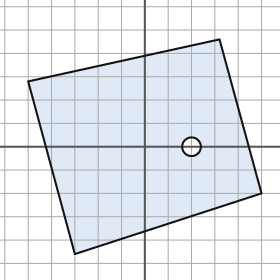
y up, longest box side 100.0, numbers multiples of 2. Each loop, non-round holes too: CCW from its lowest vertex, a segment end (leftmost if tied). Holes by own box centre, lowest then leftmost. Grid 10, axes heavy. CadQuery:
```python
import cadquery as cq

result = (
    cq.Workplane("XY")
    .moveTo(-30.0, -46.0)
    .lineTo(50.0, -20.0)
    .lineTo(32.0, 46.0)
    .lineTo(-50.0, 28.0)
    .close()
    .moveTo(20.0, 0.0)
    .circle(4.0)
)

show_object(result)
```